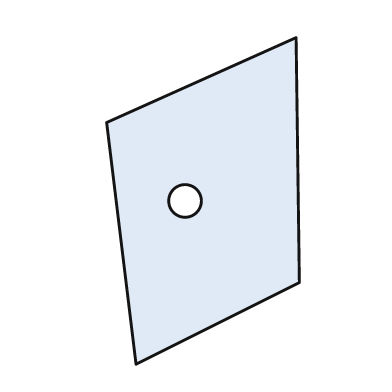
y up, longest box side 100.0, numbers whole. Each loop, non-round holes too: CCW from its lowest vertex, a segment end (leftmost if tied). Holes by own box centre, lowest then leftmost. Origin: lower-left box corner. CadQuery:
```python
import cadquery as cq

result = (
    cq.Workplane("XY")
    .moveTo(9.0, 0.0)
    .lineTo(59.0, 25.0)
    .lineTo(58.0, 100.0)
    .lineTo(0.0, 74.0)
    .close()
    .moveTo(24.0, 50.0)
    .circle(5.0)
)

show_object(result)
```